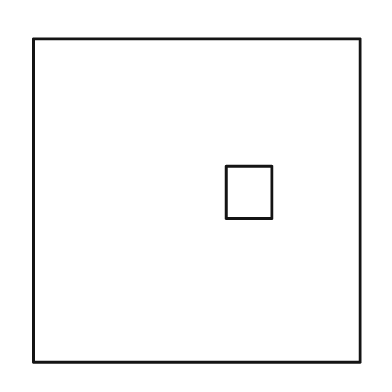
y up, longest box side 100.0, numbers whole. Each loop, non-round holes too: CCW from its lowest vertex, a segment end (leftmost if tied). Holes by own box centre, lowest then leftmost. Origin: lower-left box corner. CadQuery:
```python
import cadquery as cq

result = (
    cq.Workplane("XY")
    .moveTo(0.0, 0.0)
    .lineTo(100.0, 0.0)
    .lineTo(100.0, 99.0)
    .lineTo(0.0, 99.0)
    .close()
    .moveTo(59.0, 44.0)
    .lineTo(73.0, 44.0)
    .lineTo(73.0, 60.0)
    .lineTo(59.0, 60.0)
    .close()
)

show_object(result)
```